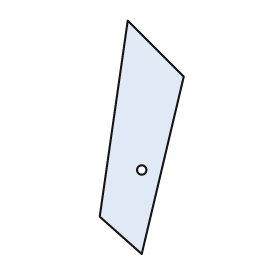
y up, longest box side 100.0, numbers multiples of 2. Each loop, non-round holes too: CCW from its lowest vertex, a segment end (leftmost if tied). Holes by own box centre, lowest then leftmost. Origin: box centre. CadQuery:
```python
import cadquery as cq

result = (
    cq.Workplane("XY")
    .moveTo(0.0, -50.0)
    .lineTo(18.0, 26.0)
    .lineTo(-6.0, 50.0)
    .lineTo(-18.0, -34.0)
    .close()
    .moveTo(0.0, -14.0)
    .circle(2.0)
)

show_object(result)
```